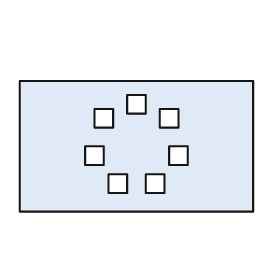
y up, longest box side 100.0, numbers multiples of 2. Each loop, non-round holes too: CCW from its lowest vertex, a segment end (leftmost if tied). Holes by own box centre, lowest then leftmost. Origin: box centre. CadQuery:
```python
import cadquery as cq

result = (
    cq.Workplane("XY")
    .moveTo(-50.0, -28.0)
    .lineTo(50.0, -28.0)
    .lineTo(50.0, 28.0)
    .lineTo(-50.0, 28.0)
    .close()
    .moveTo(-12.0, -20.0)
    .lineTo(-4.0, -20.0)
    .lineTo(-4.0, -12.0)
    .lineTo(-12.0, -12.0)
    .close()
    .moveTo(4.0, -20.0)
    .lineTo(12.0, -20.0)
    .lineTo(12.0, -12.0)
    .lineTo(4.0, -12.0)
    .close()
    .moveTo(-22.0, -8.0)
    .lineTo(-14.0, -8.0)
    .lineTo(-14.0, 0.0)
    .lineTo(-22.0, 0.0)
    .close()
    .moveTo(14.0, -8.0)
    .lineTo(22.0, -8.0)
    .lineTo(22.0, 0.0)
    .lineTo(14.0, 0.0)
    .close()
    .moveTo(-18.0, 8.0)
    .lineTo(-10.0, 8.0)
    .lineTo(-10.0, 16.0)
    .lineTo(-18.0, 16.0)
    .close()
    .moveTo(10.0, 8.0)
    .lineTo(18.0, 8.0)
    .lineTo(18.0, 16.0)
    .lineTo(10.0, 16.0)
    .close()
    .moveTo(-4.0, 14.0)
    .lineTo(4.0, 14.0)
    .lineTo(4.0, 22.0)
    .lineTo(-4.0, 22.0)
    .close()
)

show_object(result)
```